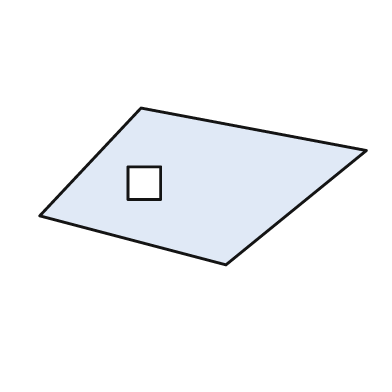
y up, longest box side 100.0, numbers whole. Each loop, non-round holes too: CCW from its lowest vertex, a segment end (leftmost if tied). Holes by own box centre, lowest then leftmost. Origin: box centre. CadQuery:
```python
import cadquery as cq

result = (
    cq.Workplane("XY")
    .moveTo(7.0, -24.0)
    .lineTo(50.0, 11.0)
    .lineTo(-19.0, 24.0)
    .lineTo(-50.0, -9.0)
    .close()
    .moveTo(-23.0, -4.0)
    .lineTo(-13.0, -4.0)
    .lineTo(-13.0, 6.0)
    .lineTo(-23.0, 6.0)
    .close()
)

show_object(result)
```